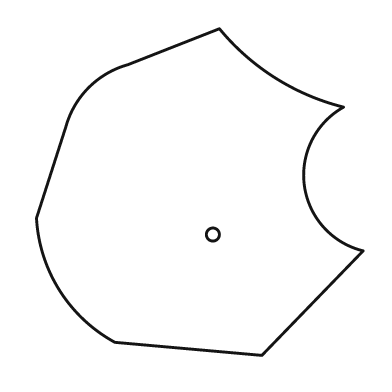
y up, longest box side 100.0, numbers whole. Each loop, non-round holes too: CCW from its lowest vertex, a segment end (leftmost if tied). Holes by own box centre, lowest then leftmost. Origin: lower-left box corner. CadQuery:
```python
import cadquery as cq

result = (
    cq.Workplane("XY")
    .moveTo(69.0, 0.0)
    .lineTo(100.0, 32.0)
    .threePointArc((82.0, 52.0), (94.0, 76.0))
    .threePointArc((73.0, 85.0), (56.0, 100.0))
    .lineTo(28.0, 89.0)
    .threePointArc((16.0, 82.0), (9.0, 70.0))
    .lineTo(0.0, 42.0)
    .threePointArc((7.0, 20.0), (24.0, 4.0))
    .close()
    .moveTo(54.0, 37.0)
    .circle(2.0)
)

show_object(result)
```